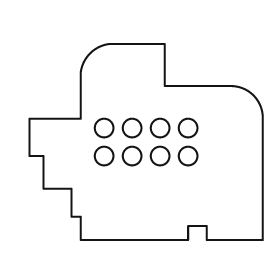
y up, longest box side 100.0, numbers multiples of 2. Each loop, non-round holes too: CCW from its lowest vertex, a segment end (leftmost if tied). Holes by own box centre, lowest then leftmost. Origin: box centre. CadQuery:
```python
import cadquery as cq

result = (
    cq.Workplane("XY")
    .moveTo(-28.0, -42.0)
    .lineTo(18.0, -42.0)
    .lineTo(18.0, -36.0)
    .lineTo(26.0, -36.0)
    .lineTo(26.0, -42.0)
    .lineTo(50.0, -42.0)
    .lineTo(50.0, 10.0)
    .threePointArc((46.0, 20.0), (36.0, 24.0))
    .lineTo(8.0, 24.0)
    .lineTo(8.0, 42.0)
    .lineTo(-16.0, 42.0)
    .threePointArc((-24.0, 38.0), (-28.0, 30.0))
    .lineTo(-28.0, 10.0)
    .lineTo(-50.0, 10.0)
    .lineTo(-50.0, -6.0)
    .lineTo(-44.0, -6.0)
    .lineTo(-44.0, -20.0)
    .lineTo(-32.0, -20.0)
    .lineTo(-32.0, -32.0)
    .lineTo(-28.0, -32.0)
    .close()
    .moveTo(-18.0, -6.0)
    .circle(4.0)
    .moveTo(-6.0, -6.0)
    .circle(4.0)
    .moveTo(6.0, -6.0)
    .circle(4.0)
    .moveTo(18.0, -6.0)
    .circle(4.0)
    .moveTo(-18.0, 6.0)
    .circle(4.0)
    .moveTo(-6.0, 6.0)
    .circle(4.0)
    .moveTo(6.0, 6.0)
    .circle(4.0)
    .moveTo(18.0, 6.0)
    .circle(4.0)
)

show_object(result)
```